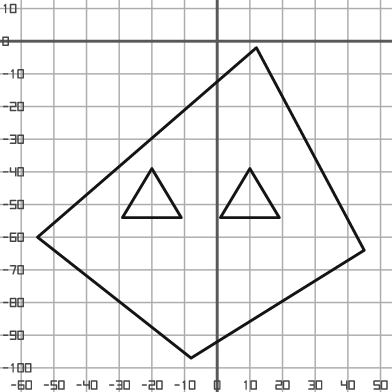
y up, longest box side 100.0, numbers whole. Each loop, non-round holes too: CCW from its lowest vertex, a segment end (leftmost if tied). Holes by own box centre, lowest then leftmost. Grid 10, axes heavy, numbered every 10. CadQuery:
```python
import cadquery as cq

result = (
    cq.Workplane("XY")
    .moveTo(-8.0, -97.0)
    .lineTo(45.0, -64.0)
    .lineTo(12.0, -2.0)
    .lineTo(-55.0, -60.0)
    .close()
    .moveTo(-29.0, -54.0)
    .lineTo(-11.0, -54.0)
    .lineTo(-20.0, -39.0)
    .close()
    .moveTo(1.0, -54.0)
    .lineTo(19.0, -54.0)
    .lineTo(10.0, -39.0)
    .close()
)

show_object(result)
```